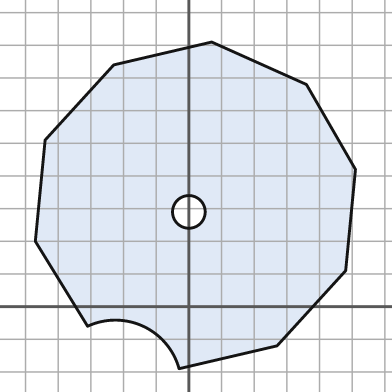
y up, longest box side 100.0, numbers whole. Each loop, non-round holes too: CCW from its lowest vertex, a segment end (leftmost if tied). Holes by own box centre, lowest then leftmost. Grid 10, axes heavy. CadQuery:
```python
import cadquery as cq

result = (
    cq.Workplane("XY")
    .moveTo(-3.0, -19.0)
    .lineTo(27.0, -12.0)
    .lineTo(48.0, 11.0)
    .lineTo(51.0, 42.0)
    .lineTo(36.0, 68.0)
    .lineTo(7.0, 81.0)
    .lineTo(-23.0, 74.0)
    .lineTo(-44.0, 51.0)
    .lineTo(-47.0, 20.0)
    .lineTo(-31.0, -6.0)
    .threePointArc((-14.0, -6.0), (-3.0, -19.0))
    .close()
    .moveTo(0.0, 29.0)
    .circle(5.0)
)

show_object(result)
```